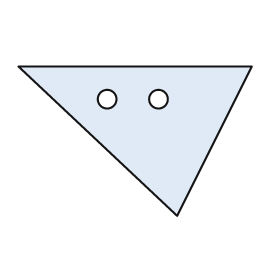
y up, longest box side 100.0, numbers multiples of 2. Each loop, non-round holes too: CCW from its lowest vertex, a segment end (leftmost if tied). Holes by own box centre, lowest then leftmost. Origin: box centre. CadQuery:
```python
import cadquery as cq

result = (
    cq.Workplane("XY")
    .moveTo(18.0, -32.0)
    .lineTo(50.0, 32.0)
    .lineTo(-50.0, 32.0)
    .close()
    .moveTo(-12.0, 18.0)
    .circle(4.0)
    .moveTo(10.0, 18.0)
    .circle(4.0)
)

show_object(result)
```